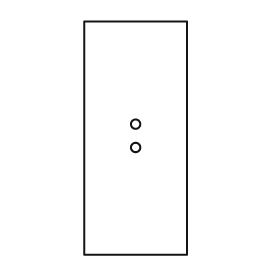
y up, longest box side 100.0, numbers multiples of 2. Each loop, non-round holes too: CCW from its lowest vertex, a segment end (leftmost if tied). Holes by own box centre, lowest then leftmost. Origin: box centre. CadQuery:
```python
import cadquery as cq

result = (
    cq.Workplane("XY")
    .moveTo(-22.0, -50.0)
    .lineTo(22.0, -50.0)
    .lineTo(22.0, 50.0)
    .lineTo(-22.0, 50.0)
    .close()
    .moveTo(0.0, -4.0)
    .circle(2.0)
    .moveTo(0.0, 6.0)
    .circle(2.0)
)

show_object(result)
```